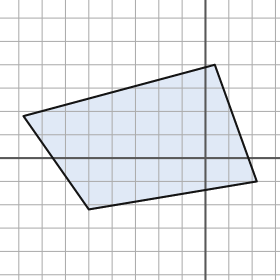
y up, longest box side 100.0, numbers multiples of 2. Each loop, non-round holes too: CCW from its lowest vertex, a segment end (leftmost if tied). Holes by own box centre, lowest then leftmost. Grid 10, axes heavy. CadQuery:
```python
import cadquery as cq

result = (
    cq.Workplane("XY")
    .moveTo(-50.0, -22.0)
    .lineTo(22.0, -10.0)
    .lineTo(4.0, 40.0)
    .lineTo(-78.0, 18.0)
    .close()
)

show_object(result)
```